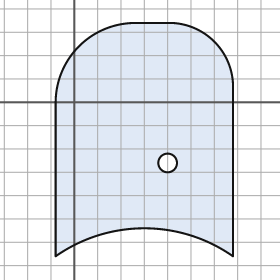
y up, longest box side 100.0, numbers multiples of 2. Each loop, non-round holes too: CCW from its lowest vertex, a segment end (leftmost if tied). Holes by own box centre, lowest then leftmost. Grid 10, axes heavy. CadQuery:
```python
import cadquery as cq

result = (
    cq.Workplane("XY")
    .moveTo(-8.0, -66.0)
    .threePointArc((30.0, -54.0), (68.0, -66.0))
    .lineTo(68.0, 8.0)
    .threePointArc((60.0, 26.0), (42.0, 34.0))
    .lineTo(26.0, 34.0)
    .threePointArc((2.0, 24.0), (-8.0, 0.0))
    .close()
    .moveTo(40.0, -26.0)
    .circle(4.0)
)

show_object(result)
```